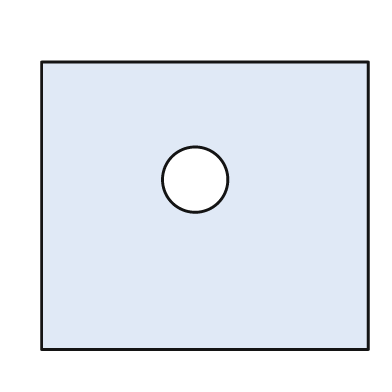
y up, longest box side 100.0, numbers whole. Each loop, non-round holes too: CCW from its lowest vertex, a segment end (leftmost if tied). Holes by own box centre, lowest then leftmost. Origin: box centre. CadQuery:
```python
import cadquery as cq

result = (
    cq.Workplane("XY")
    .moveTo(-50.0, -44.0)
    .lineTo(50.0, -44.0)
    .lineTo(50.0, 44.0)
    .lineTo(-50.0, 44.0)
    .close()
    .moveTo(-3.0, 8.0)
    .circle(10.0)
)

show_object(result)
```